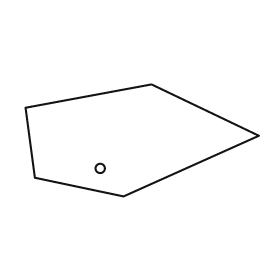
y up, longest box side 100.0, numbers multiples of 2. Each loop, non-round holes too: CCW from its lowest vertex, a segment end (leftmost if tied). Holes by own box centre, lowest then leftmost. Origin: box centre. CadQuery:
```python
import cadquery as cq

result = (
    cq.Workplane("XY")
    .moveTo(-8.0, -24.0)
    .lineTo(50.0, 2.0)
    .lineTo(4.0, 24.0)
    .lineTo(-50.0, 14.0)
    .lineTo(-46.0, -16.0)
    .close()
    .moveTo(-18.0, -12.0)
    .circle(2.0)
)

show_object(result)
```